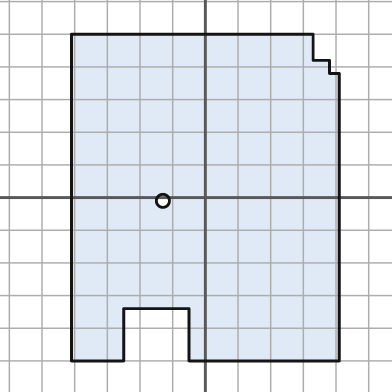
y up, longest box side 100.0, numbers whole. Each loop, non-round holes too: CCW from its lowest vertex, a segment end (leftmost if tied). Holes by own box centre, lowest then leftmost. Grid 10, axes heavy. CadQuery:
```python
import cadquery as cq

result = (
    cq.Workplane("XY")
    .moveTo(-41.0, -50.0)
    .lineTo(-25.0, -50.0)
    .lineTo(-25.0, -34.0)
    .lineTo(-5.0, -34.0)
    .lineTo(-5.0, -50.0)
    .lineTo(41.0, -50.0)
    .lineTo(41.0, 38.0)
    .lineTo(38.0, 38.0)
    .lineTo(38.0, 42.0)
    .lineTo(33.0, 42.0)
    .lineTo(33.0, 50.0)
    .lineTo(-41.0, 50.0)
    .close()
    .moveTo(-13.0, -1.0)
    .circle(2.0)
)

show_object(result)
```